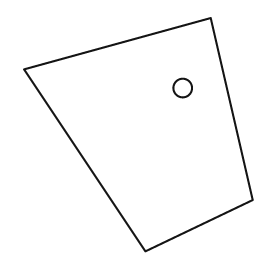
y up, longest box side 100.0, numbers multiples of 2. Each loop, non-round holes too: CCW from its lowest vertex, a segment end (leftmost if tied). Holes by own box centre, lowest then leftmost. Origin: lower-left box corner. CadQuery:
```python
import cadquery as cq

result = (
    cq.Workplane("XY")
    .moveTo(52.0, 0.0)
    .lineTo(98.0, 22.0)
    .lineTo(80.0, 100.0)
    .lineTo(0.0, 78.0)
    .close()
    .moveTo(68.0, 70.0)
    .circle(4.0)
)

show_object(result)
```